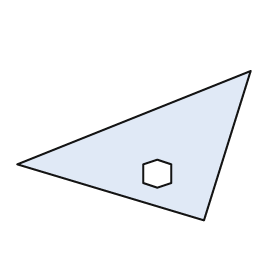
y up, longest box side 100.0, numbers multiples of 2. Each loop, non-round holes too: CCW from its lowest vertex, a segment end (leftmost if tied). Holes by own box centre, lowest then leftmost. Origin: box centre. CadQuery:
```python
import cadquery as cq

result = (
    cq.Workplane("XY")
    .moveTo(30.0, -32.0)
    .lineTo(50.0, 32.0)
    .lineTo(-50.0, -8.0)
    .close()
    .moveTo(10.0, -18.0)
    .lineTo(16.0, -16.0)
    .lineTo(16.0, -8.0)
    .lineTo(10.0, -6.0)
    .lineTo(4.0, -8.0)
    .lineTo(4.0, -16.0)
    .close()
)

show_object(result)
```